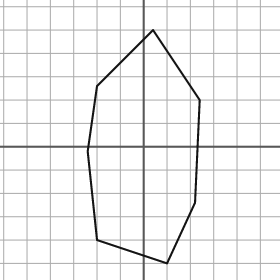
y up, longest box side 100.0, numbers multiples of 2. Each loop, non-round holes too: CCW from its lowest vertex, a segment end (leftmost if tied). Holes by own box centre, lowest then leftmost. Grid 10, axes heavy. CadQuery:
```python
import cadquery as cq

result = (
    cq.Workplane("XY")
    .moveTo(10.0, -50.0)
    .lineTo(22.0, -24.0)
    .lineTo(24.0, 20.0)
    .lineTo(4.0, 50.0)
    .lineTo(-20.0, 26.0)
    .lineTo(-24.0, -2.0)
    .lineTo(-20.0, -40.0)
    .close()
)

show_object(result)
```